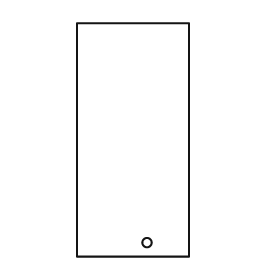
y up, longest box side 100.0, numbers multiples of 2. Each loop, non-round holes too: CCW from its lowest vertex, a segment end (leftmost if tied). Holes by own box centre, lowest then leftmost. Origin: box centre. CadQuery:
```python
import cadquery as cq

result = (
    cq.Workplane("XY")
    .moveTo(-24.0, -50.0)
    .lineTo(24.0, -50.0)
    .lineTo(24.0, 50.0)
    .lineTo(-24.0, 50.0)
    .close()
    .moveTo(6.0, -44.0)
    .circle(2.0)
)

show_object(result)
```